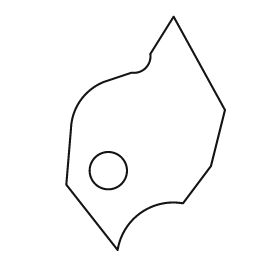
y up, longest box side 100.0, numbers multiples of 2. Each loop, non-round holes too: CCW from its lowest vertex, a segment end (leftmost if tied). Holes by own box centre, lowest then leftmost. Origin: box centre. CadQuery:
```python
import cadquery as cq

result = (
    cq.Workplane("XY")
    .moveTo(-12.0, -50.0)
    .threePointArc((-2.0, -34.0), (16.0, -30.0))
    .lineTo(28.0, -14.0)
    .lineTo(34.0, 10.0)
    .lineTo(12.0, 50.0)
    .lineTo(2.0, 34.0)
    .threePointArc((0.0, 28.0), (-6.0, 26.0))
    .lineTo(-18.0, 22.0)
    .threePointArc((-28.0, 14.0), (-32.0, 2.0))
    .lineTo(-34.0, -22.0)
    .close()
    .moveTo(-16.0, -16.0)
    .circle(8.0)
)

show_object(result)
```